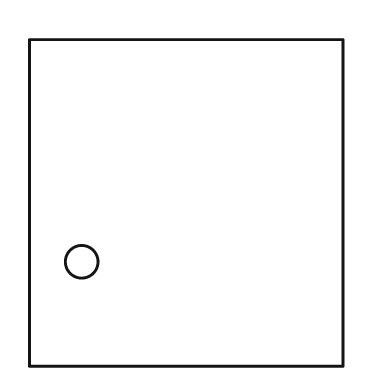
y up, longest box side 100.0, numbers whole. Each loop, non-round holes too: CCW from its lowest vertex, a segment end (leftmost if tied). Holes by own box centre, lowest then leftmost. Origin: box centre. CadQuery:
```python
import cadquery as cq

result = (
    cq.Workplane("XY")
    .moveTo(-48.0, -50.0)
    .lineTo(48.0, -50.0)
    .lineTo(48.0, 50.0)
    .lineTo(-48.0, 50.0)
    .close()
    .moveTo(-32.0, -18.0)
    .circle(5.0)
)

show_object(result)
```